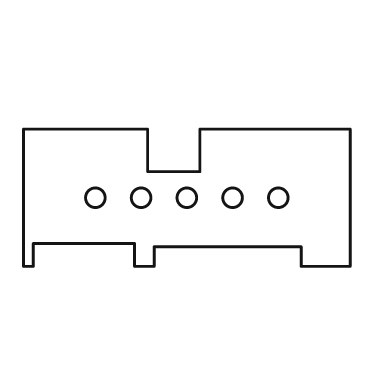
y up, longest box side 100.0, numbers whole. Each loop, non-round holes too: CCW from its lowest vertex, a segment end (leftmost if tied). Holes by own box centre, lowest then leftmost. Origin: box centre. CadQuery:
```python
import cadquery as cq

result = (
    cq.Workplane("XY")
    .moveTo(-50.0, -21.0)
    .lineTo(-47.0, -21.0)
    .lineTo(-47.0, -14.0)
    .lineTo(-16.0, -14.0)
    .lineTo(-16.0, -21.0)
    .lineTo(-10.0, -21.0)
    .lineTo(-10.0, -15.0)
    .lineTo(35.0, -15.0)
    .lineTo(35.0, -21.0)
    .lineTo(50.0, -21.0)
    .lineTo(50.0, 21.0)
    .lineTo(4.0, 21.0)
    .lineTo(4.0, 8.0)
    .lineTo(-12.0, 8.0)
    .lineTo(-12.0, 21.0)
    .lineTo(-50.0, 21.0)
    .close()
    .moveTo(-28.0, 0.0)
    .circle(3.0)
    .moveTo(-14.0, 0.0)
    .circle(3.0)
    .moveTo(0.0, 0.0)
    .circle(3.0)
    .moveTo(14.0, 0.0)
    .circle(3.0)
    .moveTo(28.0, 0.0)
    .circle(3.0)
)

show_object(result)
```